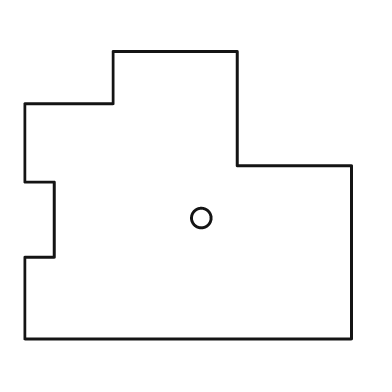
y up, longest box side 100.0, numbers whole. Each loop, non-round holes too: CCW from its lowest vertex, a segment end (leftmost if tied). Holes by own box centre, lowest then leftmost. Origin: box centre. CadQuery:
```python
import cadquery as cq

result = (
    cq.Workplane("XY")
    .moveTo(-50.0, -44.0)
    .lineTo(50.0, -44.0)
    .lineTo(50.0, 9.0)
    .lineTo(15.0, 9.0)
    .lineTo(15.0, 44.0)
    .lineTo(-23.0, 44.0)
    .lineTo(-23.0, 28.0)
    .lineTo(-50.0, 28.0)
    .lineTo(-50.0, 4.0)
    .lineTo(-41.0, 4.0)
    .lineTo(-41.0, -19.0)
    .lineTo(-50.0, -19.0)
    .close()
    .moveTo(4.0, -7.0)
    .circle(3.0)
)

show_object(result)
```